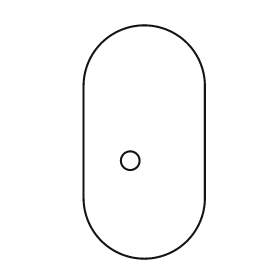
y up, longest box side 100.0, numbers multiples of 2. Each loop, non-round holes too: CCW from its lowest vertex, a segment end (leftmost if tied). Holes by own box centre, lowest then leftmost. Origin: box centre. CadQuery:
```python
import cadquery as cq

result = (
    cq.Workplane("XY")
    .moveTo(-26.0, -24.0)
    .threePointArc((0.0, -50.0), (26.0, -24.0))
    .lineTo(26.0, 24.0)
    .threePointArc((0.0, 50.0), (-26.0, 24.0))
    .close()
    .moveTo(-6.0, -8.0)
    .circle(4.0)
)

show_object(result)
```